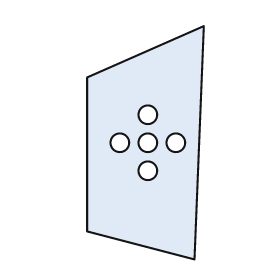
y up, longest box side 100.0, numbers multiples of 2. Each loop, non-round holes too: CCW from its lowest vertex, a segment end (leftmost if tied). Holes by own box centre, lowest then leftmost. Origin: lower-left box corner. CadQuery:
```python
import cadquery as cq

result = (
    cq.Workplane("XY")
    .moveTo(46.0, 0.0)
    .lineTo(50.0, 100.0)
    .lineTo(0.0, 78.0)
    .lineTo(0.0, 12.0)
    .close()
    .moveTo(26.0, 38.0)
    .circle(4.0)
    .moveTo(14.0, 50.0)
    .circle(4.0)
    .moveTo(26.0, 50.0)
    .circle(4.0)
    .moveTo(38.0, 50.0)
    .circle(4.0)
    .moveTo(26.0, 62.0)
    .circle(4.0)
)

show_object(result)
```